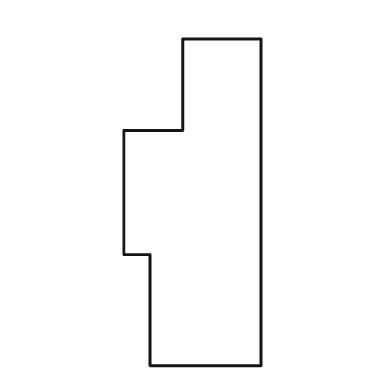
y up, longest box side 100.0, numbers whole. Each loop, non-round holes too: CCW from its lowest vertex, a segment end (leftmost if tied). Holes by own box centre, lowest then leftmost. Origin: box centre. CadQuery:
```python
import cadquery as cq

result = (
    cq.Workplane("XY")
    .moveTo(-13.0, -50.0)
    .lineTo(21.0, -50.0)
    .lineTo(21.0, 50.0)
    .lineTo(-3.0, 50.0)
    .lineTo(-3.0, 22.0)
    .lineTo(-21.0, 22.0)
    .lineTo(-21.0, -16.0)
    .lineTo(-13.0, -16.0)
    .close()
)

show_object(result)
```